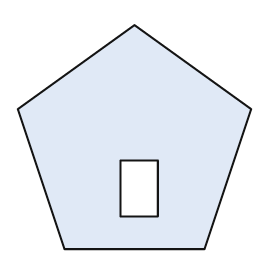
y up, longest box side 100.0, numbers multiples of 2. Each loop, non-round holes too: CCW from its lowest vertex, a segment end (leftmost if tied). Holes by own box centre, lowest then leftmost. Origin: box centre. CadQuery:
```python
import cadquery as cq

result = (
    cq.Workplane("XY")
    .moveTo(-30.0, -48.0)
    .lineTo(30.0, -48.0)
    .lineTo(50.0, 12.0)
    .lineTo(0.0, 48.0)
    .lineTo(-50.0, 12.0)
    .close()
    .moveTo(-6.0, -34.0)
    .lineTo(10.0, -34.0)
    .lineTo(10.0, -10.0)
    .lineTo(-6.0, -10.0)
    .close()
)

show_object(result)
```